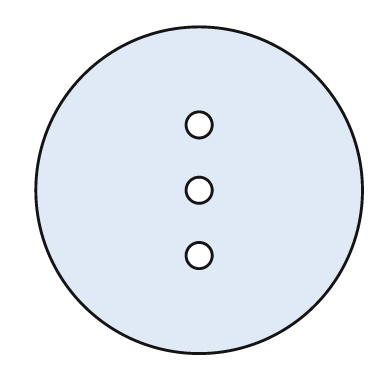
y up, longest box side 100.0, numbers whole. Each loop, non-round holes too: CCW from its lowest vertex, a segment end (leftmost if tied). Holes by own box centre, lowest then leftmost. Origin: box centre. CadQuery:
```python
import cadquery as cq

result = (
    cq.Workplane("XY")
    .moveTo(0.0, 0.0)
    .circle(50.0)
    .moveTo(0.0, -20.0)
    .circle(4.0)
    .moveTo(0.0, 0.0)
    .circle(4.0)
    .moveTo(0.0, 20.0)
    .circle(4.0)
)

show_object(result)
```